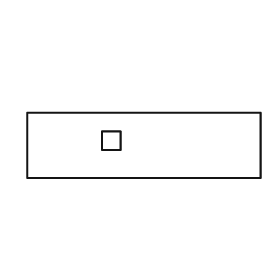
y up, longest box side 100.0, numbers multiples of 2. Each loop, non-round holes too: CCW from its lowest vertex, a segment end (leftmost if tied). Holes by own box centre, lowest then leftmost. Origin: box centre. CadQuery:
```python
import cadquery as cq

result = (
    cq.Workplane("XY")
    .moveTo(-50.0, -14.0)
    .lineTo(50.0, -14.0)
    .lineTo(50.0, 14.0)
    .lineTo(-50.0, 14.0)
    .close()
    .moveTo(-18.0, -2.0)
    .lineTo(-10.0, -2.0)
    .lineTo(-10.0, 6.0)
    .lineTo(-18.0, 6.0)
    .close()
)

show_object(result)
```